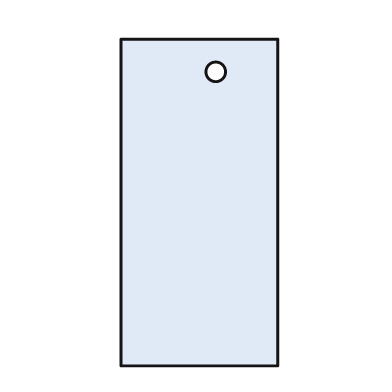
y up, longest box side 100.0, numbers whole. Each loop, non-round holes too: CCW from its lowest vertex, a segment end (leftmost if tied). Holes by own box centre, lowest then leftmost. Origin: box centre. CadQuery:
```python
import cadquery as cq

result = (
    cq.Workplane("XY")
    .moveTo(-24.0, -50.0)
    .lineTo(24.0, -50.0)
    .lineTo(24.0, 50.0)
    .lineTo(-24.0, 50.0)
    .close()
    .moveTo(5.0, 40.0)
    .circle(3.0)
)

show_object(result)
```